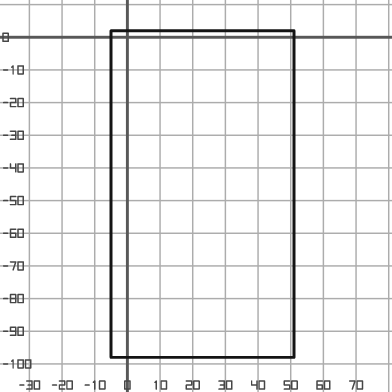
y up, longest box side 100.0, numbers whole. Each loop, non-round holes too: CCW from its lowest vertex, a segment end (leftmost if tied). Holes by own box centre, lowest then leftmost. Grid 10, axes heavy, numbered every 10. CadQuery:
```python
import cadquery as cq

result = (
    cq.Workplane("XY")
    .moveTo(-5.0, -98.0)
    .lineTo(51.0, -98.0)
    .lineTo(51.0, 2.0)
    .lineTo(-5.0, 2.0)
    .close()
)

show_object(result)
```